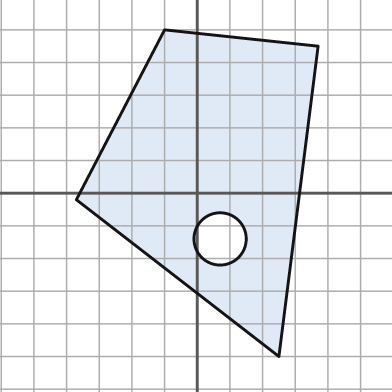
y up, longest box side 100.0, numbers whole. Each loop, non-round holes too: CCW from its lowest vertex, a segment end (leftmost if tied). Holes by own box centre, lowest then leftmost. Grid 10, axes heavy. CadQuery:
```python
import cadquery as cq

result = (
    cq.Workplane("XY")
    .moveTo(25.0, -50.0)
    .lineTo(37.0, 45.0)
    .lineTo(-10.0, 50.0)
    .lineTo(-37.0, -2.0)
    .close()
    .moveTo(7.0, -14.0)
    .circle(8.0)
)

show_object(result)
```